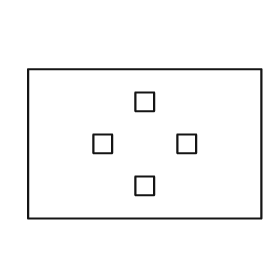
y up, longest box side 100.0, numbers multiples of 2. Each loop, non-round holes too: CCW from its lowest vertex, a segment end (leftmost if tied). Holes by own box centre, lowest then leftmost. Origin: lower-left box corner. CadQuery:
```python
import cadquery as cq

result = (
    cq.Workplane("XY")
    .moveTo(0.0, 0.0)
    .lineTo(100.0, 0.0)
    .lineTo(100.0, 64.0)
    .lineTo(0.0, 64.0)
    .close()
    .moveTo(46.0, 10.0)
    .lineTo(54.0, 10.0)
    .lineTo(54.0, 18.0)
    .lineTo(46.0, 18.0)
    .close()
    .moveTo(28.0, 28.0)
    .lineTo(36.0, 28.0)
    .lineTo(36.0, 36.0)
    .lineTo(28.0, 36.0)
    .close()
    .moveTo(64.0, 28.0)
    .lineTo(72.0, 28.0)
    .lineTo(72.0, 36.0)
    .lineTo(64.0, 36.0)
    .close()
    .moveTo(46.0, 46.0)
    .lineTo(54.0, 46.0)
    .lineTo(54.0, 54.0)
    .lineTo(46.0, 54.0)
    .close()
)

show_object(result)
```